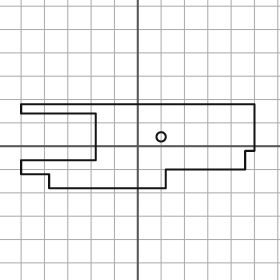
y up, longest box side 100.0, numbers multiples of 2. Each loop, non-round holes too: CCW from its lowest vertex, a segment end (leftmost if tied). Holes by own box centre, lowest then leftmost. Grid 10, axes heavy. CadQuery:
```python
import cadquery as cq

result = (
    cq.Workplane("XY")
    .moveTo(-38.0, -18.0)
    .lineTo(12.0, -18.0)
    .lineTo(12.0, -10.0)
    .lineTo(46.0, -10.0)
    .lineTo(46.0, -2.0)
    .lineTo(50.0, -2.0)
    .lineTo(50.0, 18.0)
    .lineTo(-50.0, 18.0)
    .lineTo(-50.0, 14.0)
    .lineTo(-18.0, 14.0)
    .lineTo(-18.0, -6.0)
    .lineTo(-50.0, -6.0)
    .lineTo(-50.0, -12.0)
    .lineTo(-38.0, -12.0)
    .close()
    .moveTo(10.0, 4.0)
    .circle(2.0)
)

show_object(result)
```